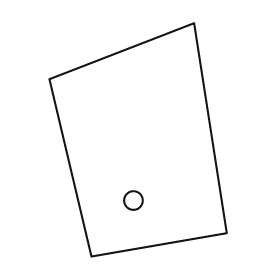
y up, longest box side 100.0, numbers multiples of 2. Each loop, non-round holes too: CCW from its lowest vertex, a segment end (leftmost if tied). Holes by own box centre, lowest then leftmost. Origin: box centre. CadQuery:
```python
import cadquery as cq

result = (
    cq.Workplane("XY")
    .moveTo(-20.0, -50.0)
    .lineTo(38.0, -40.0)
    .lineTo(24.0, 50.0)
    .lineTo(-38.0, 26.0)
    .close()
    .moveTo(-2.0, -26.0)
    .circle(4.0)
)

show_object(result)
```